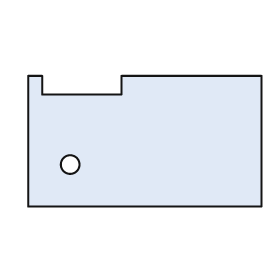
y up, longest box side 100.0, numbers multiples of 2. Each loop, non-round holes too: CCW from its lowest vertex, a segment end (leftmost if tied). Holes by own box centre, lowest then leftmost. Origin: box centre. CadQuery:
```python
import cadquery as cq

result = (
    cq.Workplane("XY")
    .moveTo(-50.0, -28.0)
    .lineTo(50.0, -28.0)
    .lineTo(50.0, 28.0)
    .lineTo(-10.0, 28.0)
    .lineTo(-10.0, 20.0)
    .lineTo(-44.0, 20.0)
    .lineTo(-44.0, 28.0)
    .lineTo(-50.0, 28.0)
    .close()
    .moveTo(-32.0, -10.0)
    .circle(4.0)
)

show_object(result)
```